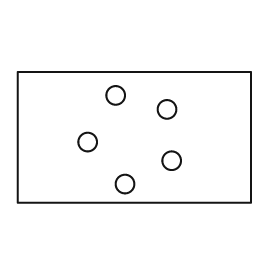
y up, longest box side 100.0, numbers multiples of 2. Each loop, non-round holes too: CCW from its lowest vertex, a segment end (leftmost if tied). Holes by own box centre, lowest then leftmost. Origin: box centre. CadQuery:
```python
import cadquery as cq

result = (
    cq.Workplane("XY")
    .moveTo(-50.0, -28.0)
    .lineTo(50.0, -28.0)
    .lineTo(50.0, 28.0)
    .lineTo(-50.0, 28.0)
    .close()
    .moveTo(-4.0, -20.0)
    .circle(4.0)
    .moveTo(16.0, -10.0)
    .circle(4.0)
    .moveTo(-20.0, -2.0)
    .circle(4.0)
    .moveTo(14.0, 12.0)
    .circle(4.0)
    .moveTo(-8.0, 18.0)
    .circle(4.0)
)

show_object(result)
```